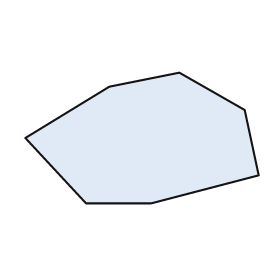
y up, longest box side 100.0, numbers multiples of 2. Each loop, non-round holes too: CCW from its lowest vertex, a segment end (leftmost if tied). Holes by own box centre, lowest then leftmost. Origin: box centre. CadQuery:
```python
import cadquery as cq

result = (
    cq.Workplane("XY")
    .moveTo(-24.0, -28.0)
    .lineTo(4.0, -28.0)
    .lineTo(50.0, -16.0)
    .lineTo(44.0, 12.0)
    .lineTo(16.0, 28.0)
    .lineTo(-14.0, 22.0)
    .lineTo(-50.0, 0.0)
    .close()
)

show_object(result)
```